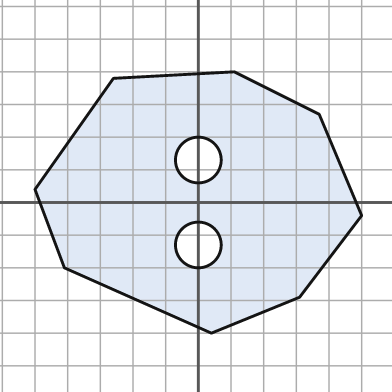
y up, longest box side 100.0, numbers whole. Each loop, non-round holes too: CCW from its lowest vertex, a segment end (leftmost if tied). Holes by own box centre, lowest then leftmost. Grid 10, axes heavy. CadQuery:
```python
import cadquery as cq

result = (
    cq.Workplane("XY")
    .moveTo(4.0, -40.0)
    .lineTo(31.0, -29.0)
    .lineTo(50.0, -4.0)
    .lineTo(37.0, 27.0)
    .lineTo(11.0, 40.0)
    .lineTo(-26.0, 38.0)
    .lineTo(-50.0, 4.0)
    .lineTo(-41.0, -20.0)
    .close()
    .moveTo(0.0, -13.0)
    .circle(7.0)
    .moveTo(0.0, 13.0)
    .circle(7.0)
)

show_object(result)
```